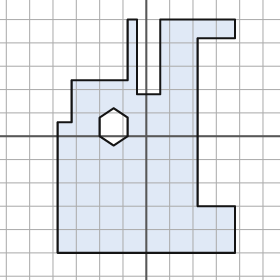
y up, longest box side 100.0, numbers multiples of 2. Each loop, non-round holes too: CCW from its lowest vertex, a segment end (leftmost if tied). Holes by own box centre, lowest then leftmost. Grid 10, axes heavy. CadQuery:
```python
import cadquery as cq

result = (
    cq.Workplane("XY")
    .moveTo(-38.0, -50.0)
    .lineTo(38.0, -50.0)
    .lineTo(38.0, -30.0)
    .lineTo(22.0, -30.0)
    .lineTo(22.0, 42.0)
    .lineTo(38.0, 42.0)
    .lineTo(38.0, 50.0)
    .lineTo(6.0, 50.0)
    .lineTo(6.0, 18.0)
    .lineTo(-4.0, 18.0)
    .lineTo(-4.0, 50.0)
    .lineTo(-8.0, 50.0)
    .lineTo(-8.0, 24.0)
    .lineTo(-32.0, 24.0)
    .lineTo(-32.0, 6.0)
    .lineTo(-38.0, 6.0)
    .close()
    .moveTo(-14.0, -4.0)
    .lineTo(-8.0, 0.0)
    .lineTo(-8.0, 8.0)
    .lineTo(-14.0, 12.0)
    .lineTo(-20.0, 8.0)
    .lineTo(-20.0, 0.0)
    .close()
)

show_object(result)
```